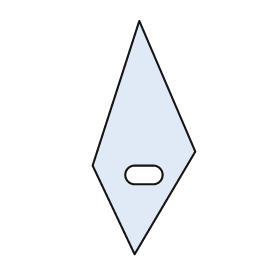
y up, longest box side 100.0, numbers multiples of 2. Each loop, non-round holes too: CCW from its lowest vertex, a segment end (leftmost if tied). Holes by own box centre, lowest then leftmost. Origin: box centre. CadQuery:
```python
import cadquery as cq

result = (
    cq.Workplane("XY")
    .moveTo(-4.0, -50.0)
    .lineTo(22.0, -6.0)
    .lineTo(-2.0, 50.0)
    .lineTo(-22.0, -12.0)
    .close()
    .moveTo(-4.0, -20.0)
    .lineTo(4.0, -20.0)
    .threePointArc((8.0, -16.0), (4.0, -12.0))
    .lineTo(-4.0, -12.0)
    .threePointArc((-8.0, -16.0), (-4.0, -20.0))
    .close()
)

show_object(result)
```